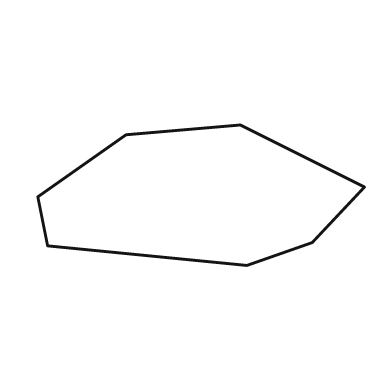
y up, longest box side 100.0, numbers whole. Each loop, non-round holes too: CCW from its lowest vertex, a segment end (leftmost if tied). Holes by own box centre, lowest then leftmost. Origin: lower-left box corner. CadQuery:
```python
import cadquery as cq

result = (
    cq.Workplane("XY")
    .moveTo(64.0, 0.0)
    .lineTo(84.0, 7.0)
    .lineTo(100.0, 24.0)
    .lineTo(62.0, 43.0)
    .lineTo(27.0, 40.0)
    .lineTo(0.0, 21.0)
    .lineTo(3.0, 6.0)
    .close()
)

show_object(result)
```